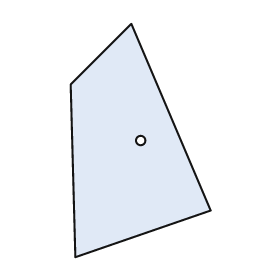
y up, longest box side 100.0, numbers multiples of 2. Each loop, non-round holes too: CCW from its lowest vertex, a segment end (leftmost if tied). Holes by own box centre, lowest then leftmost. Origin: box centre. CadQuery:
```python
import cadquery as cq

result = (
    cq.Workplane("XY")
    .moveTo(-28.0, -50.0)
    .lineTo(30.0, -30.0)
    .lineTo(-4.0, 50.0)
    .lineTo(-30.0, 24.0)
    .close()
    .moveTo(0.0, 0.0)
    .circle(2.0)
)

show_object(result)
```